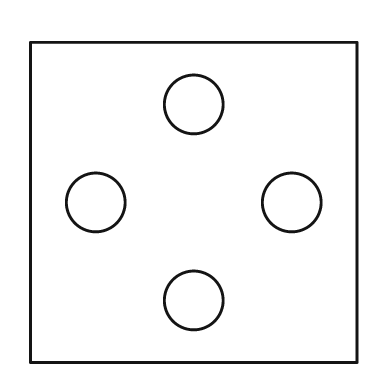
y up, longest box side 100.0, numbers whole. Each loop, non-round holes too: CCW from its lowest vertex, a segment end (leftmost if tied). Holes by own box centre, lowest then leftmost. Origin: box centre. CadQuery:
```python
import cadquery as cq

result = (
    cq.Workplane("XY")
    .moveTo(-50.0, -49.0)
    .lineTo(50.0, -49.0)
    .lineTo(50.0, 49.0)
    .lineTo(-50.0, 49.0)
    .close()
    .moveTo(0.0, -30.0)
    .circle(9.0)
    .moveTo(-30.0, 0.0)
    .circle(9.0)
    .moveTo(30.0, 0.0)
    .circle(9.0)
    .moveTo(0.0, 30.0)
    .circle(9.0)
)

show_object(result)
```